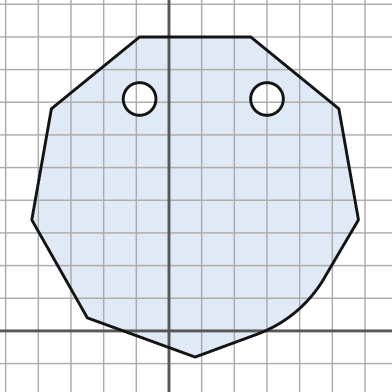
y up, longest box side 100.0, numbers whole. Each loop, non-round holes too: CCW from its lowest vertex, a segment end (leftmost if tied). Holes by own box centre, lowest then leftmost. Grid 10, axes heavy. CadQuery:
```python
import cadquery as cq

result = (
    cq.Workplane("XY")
    .moveTo(8.0, -8.0)
    .lineTo(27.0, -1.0)
    .threePointArc((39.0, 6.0), (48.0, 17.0))
    .lineTo(58.0, 34.0)
    .lineTo(52.0, 68.0)
    .lineTo(25.0, 90.0)
    .lineTo(-9.0, 90.0)
    .lineTo(-36.0, 68.0)
    .lineTo(-42.0, 34.0)
    .lineTo(-25.0, 4.0)
    .close()
    .moveTo(-9.0, 71.0)
    .circle(5.0)
    .moveTo(30.0, 71.0)
    .circle(5.0)
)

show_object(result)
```